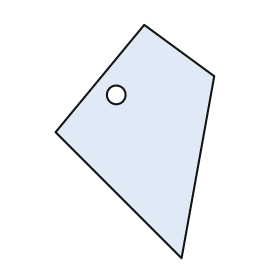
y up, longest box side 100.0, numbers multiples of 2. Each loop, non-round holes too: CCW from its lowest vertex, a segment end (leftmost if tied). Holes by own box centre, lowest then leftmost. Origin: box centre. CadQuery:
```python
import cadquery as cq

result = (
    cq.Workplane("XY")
    .moveTo(20.0, -50.0)
    .lineTo(34.0, 28.0)
    .lineTo(4.0, 50.0)
    .lineTo(-34.0, 4.0)
    .close()
    .moveTo(-8.0, 20.0)
    .circle(4.0)
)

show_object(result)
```